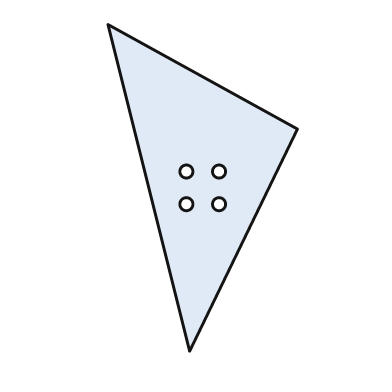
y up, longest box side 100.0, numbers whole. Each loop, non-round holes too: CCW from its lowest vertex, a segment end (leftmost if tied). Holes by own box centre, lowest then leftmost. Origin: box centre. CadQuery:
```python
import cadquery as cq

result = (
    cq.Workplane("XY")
    .moveTo(-4.0, -50.0)
    .lineTo(29.0, 18.0)
    .lineTo(-29.0, 50.0)
    .close()
    .moveTo(-5.0, -5.0)
    .circle(2.0)
    .moveTo(5.0, -5.0)
    .circle(2.0)
    .moveTo(-5.0, 5.0)
    .circle(2.0)
    .moveTo(5.0, 5.0)
    .circle(2.0)
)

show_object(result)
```